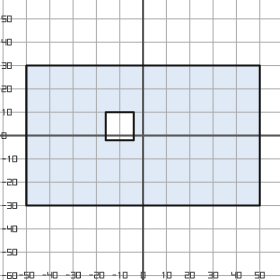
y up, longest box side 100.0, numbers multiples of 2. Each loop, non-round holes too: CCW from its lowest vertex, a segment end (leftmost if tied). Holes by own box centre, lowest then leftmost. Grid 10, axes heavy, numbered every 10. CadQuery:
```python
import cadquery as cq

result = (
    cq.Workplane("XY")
    .moveTo(-50.0, -30.0)
    .lineTo(50.0, -30.0)
    .lineTo(50.0, 30.0)
    .lineTo(-50.0, 30.0)
    .close()
    .moveTo(-16.0, -2.0)
    .lineTo(-4.0, -2.0)
    .lineTo(-4.0, 10.0)
    .lineTo(-16.0, 10.0)
    .close()
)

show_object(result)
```